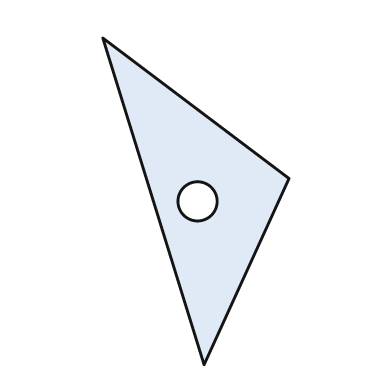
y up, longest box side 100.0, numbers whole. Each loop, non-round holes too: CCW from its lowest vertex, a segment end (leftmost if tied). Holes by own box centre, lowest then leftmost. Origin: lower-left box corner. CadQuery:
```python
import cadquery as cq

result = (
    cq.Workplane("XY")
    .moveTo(31.0, 0.0)
    .lineTo(57.0, 57.0)
    .lineTo(0.0, 100.0)
    .close()
    .moveTo(29.0, 50.0)
    .circle(6.0)
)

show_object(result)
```